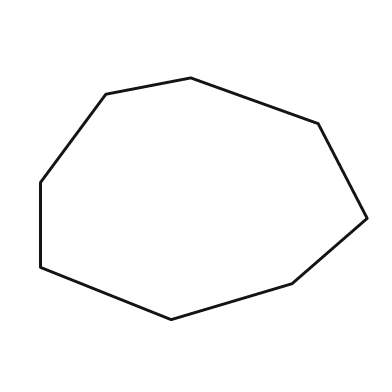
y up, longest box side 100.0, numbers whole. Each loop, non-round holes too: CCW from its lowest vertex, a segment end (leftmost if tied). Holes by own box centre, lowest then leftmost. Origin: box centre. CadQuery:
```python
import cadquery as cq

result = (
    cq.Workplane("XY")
    .moveTo(-10.0, -37.0)
    .lineTo(27.0, -26.0)
    .lineTo(50.0, -6.0)
    .lineTo(35.0, 23.0)
    .lineTo(-4.0, 37.0)
    .lineTo(-30.0, 32.0)
    .lineTo(-50.0, 5.0)
    .lineTo(-50.0, -21.0)
    .close()
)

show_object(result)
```